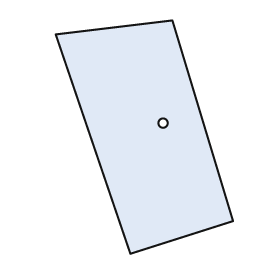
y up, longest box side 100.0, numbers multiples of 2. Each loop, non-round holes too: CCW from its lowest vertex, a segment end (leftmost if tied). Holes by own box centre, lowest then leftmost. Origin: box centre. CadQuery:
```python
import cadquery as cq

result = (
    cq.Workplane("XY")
    .moveTo(-6.0, -50.0)
    .lineTo(38.0, -36.0)
    .lineTo(12.0, 50.0)
    .lineTo(-38.0, 44.0)
    .close()
    .moveTo(8.0, 6.0)
    .circle(2.0)
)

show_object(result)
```